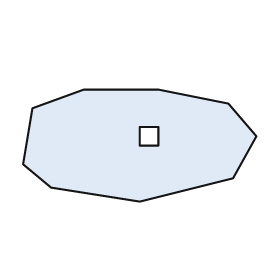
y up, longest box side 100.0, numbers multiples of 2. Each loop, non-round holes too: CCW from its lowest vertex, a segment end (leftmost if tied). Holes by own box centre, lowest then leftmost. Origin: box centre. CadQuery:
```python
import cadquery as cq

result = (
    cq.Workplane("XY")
    .moveTo(0.0, -24.0)
    .lineTo(40.0, -14.0)
    .lineTo(50.0, 4.0)
    .lineTo(38.0, 18.0)
    .lineTo(8.0, 24.0)
    .lineTo(-24.0, 24.0)
    .lineTo(-46.0, 16.0)
    .lineTo(-50.0, -8.0)
    .lineTo(-38.0, -18.0)
    .close()
    .moveTo(0.0, 0.0)
    .lineTo(8.0, 0.0)
    .lineTo(8.0, 8.0)
    .lineTo(0.0, 8.0)
    .close()
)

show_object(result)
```